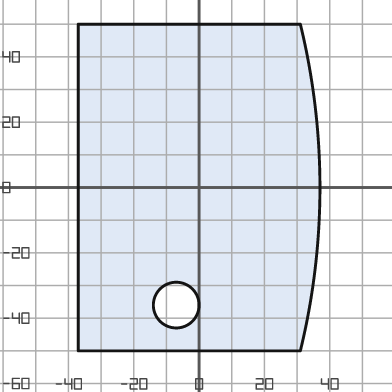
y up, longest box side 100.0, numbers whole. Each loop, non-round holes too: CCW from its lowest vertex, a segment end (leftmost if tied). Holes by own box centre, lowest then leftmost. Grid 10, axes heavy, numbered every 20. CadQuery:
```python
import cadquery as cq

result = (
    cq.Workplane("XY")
    .moveTo(-37.0, -50.0)
    .lineTo(31.0, -50.0)
    .threePointArc((37.0, 0.0), (31.0, 50.0))
    .lineTo(-37.0, 50.0)
    .close()
    .moveTo(-7.0, -36.0)
    .circle(7.0)
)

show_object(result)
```